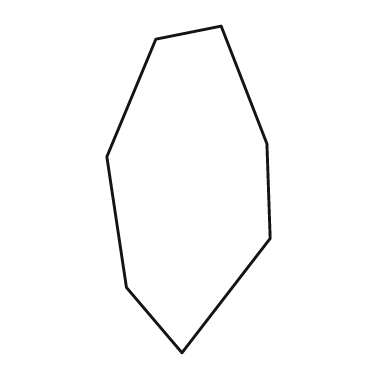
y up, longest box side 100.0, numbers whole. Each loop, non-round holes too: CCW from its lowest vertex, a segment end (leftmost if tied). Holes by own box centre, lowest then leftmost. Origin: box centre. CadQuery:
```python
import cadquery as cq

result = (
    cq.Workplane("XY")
    .moveTo(-2.0, -50.0)
    .lineTo(25.0, -15.0)
    .lineTo(24.0, 14.0)
    .lineTo(10.0, 50.0)
    .lineTo(-10.0, 46.0)
    .lineTo(-25.0, 10.0)
    .lineTo(-19.0, -30.0)
    .close()
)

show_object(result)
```